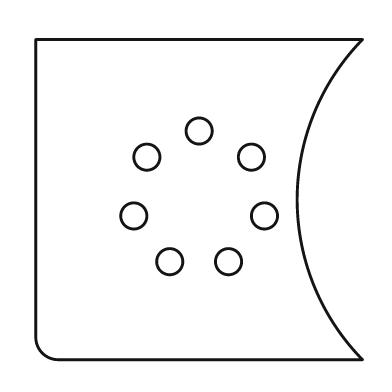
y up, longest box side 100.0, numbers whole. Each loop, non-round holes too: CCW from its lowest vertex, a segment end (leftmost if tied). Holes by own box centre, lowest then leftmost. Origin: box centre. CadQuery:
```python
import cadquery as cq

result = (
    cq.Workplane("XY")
    .moveTo(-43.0, -49.0)
    .lineTo(50.0, -49.0)
    .threePointArc((30.0, 0.0), (50.0, 49.0))
    .lineTo(-50.0, 49.0)
    .lineTo(-50.0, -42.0)
    .threePointArc((-48.0, -47.0), (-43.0, -49.0))
    .close()
    .moveTo(-9.0, -19.0)
    .circle(4.0)
    .moveTo(9.0, -19.0)
    .circle(4.0)
    .moveTo(-20.0, -5.0)
    .circle(4.0)
    .moveTo(20.0, -5.0)
    .circle(4.0)
    .moveTo(-16.0, 13.0)
    .circle(4.0)
    .moveTo(16.0, 13.0)
    .circle(4.0)
    .moveTo(0.0, 21.0)
    .circle(4.0)
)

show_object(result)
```